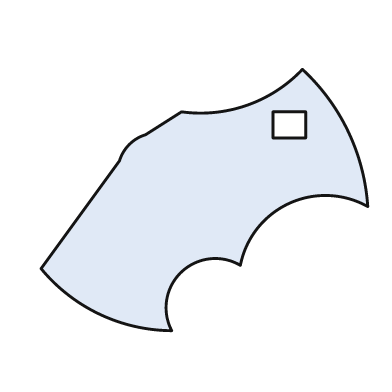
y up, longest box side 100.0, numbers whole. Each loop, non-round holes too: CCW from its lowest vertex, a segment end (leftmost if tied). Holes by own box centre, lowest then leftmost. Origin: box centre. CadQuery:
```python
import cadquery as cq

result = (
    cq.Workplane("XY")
    .moveTo(-10.0, -40.0)
    .threePointArc((-7.0, -22.0), (11.0, -20.0))
    .threePointArc((26.0, -1.0), (50.0, -2.0))
    .threePointArc((44.0, 21.0), (30.0, 40.0))
    .threePointArc((13.0, 29.0), (-7.0, 27.0))
    .lineTo(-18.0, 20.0)
    .threePointArc((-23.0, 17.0), (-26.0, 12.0))
    .lineTo(-50.0, -21.0)
    .threePointArc((-32.0, -35.0), (-10.0, -40.0))
    .close()
    .moveTo(21.0, 19.0)
    .lineTo(31.0, 19.0)
    .lineTo(31.0, 27.0)
    .lineTo(21.0, 27.0)
    .close()
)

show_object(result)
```